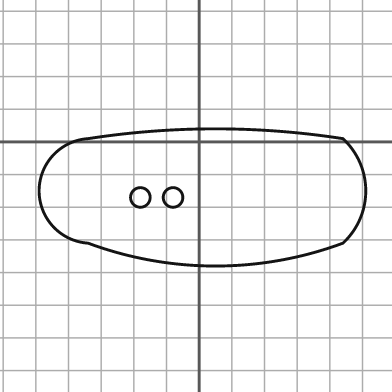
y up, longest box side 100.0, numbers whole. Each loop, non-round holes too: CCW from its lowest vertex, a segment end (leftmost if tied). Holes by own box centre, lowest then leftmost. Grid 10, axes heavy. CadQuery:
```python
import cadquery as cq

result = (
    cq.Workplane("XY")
    .moveTo(-34.0, -31.0)
    .threePointArc((5.0, -38.0), (44.0, -31.0))
    .threePointArc((51.0, -15.0), (44.0, 1.0))
    .threePointArc((5.0, 4.0), (-34.0, 1.0))
    .threePointArc((-49.0, -15.0), (-34.0, -31.0))
    .close()
    .moveTo(-18.0, -17.0)
    .circle(3.0)
    .moveTo(-8.0, -17.0)
    .circle(3.0)
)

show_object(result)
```